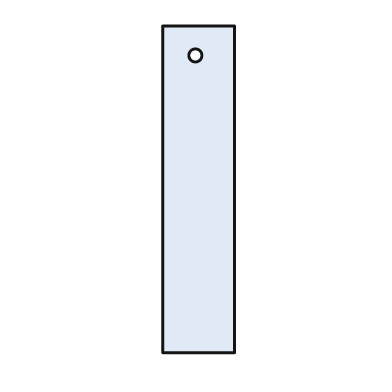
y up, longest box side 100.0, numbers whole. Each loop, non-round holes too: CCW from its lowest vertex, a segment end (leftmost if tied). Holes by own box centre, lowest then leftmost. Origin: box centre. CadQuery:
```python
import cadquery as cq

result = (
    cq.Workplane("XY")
    .moveTo(-11.0, -50.0)
    .lineTo(11.0, -50.0)
    .lineTo(11.0, 50.0)
    .lineTo(-11.0, 50.0)
    .close()
    .moveTo(-1.0, 41.0)
    .circle(2.0)
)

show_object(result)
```